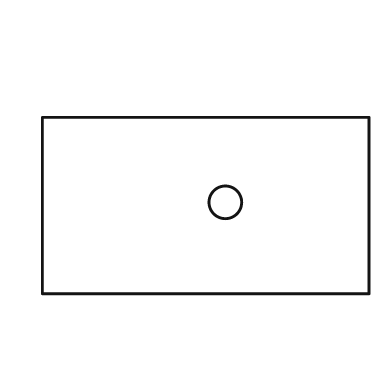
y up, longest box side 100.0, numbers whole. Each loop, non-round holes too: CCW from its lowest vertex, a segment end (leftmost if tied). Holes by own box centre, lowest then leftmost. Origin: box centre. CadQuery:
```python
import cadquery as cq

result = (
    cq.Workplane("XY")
    .moveTo(-50.0, -27.0)
    .lineTo(50.0, -27.0)
    .lineTo(50.0, 27.0)
    .lineTo(-50.0, 27.0)
    .close()
    .moveTo(6.0, 1.0)
    .circle(5.0)
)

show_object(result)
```